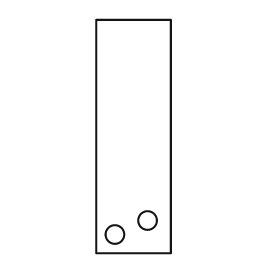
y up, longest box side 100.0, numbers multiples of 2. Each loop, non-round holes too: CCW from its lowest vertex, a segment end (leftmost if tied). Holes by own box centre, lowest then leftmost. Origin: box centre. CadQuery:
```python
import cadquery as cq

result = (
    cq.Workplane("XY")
    .moveTo(-16.0, -50.0)
    .lineTo(16.0, -50.0)
    .lineTo(16.0, 50.0)
    .lineTo(-16.0, 50.0)
    .close()
    .moveTo(-8.0, -42.0)
    .circle(4.0)
    .moveTo(6.0, -36.0)
    .circle(4.0)
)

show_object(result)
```